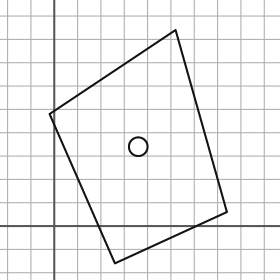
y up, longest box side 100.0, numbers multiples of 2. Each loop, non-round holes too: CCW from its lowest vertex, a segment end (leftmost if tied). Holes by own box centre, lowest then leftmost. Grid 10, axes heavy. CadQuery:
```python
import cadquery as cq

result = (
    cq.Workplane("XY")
    .moveTo(26.0, -16.0)
    .lineTo(74.0, 6.0)
    .lineTo(52.0, 84.0)
    .lineTo(-2.0, 48.0)
    .close()
    .moveTo(36.0, 34.0)
    .circle(4.0)
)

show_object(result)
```